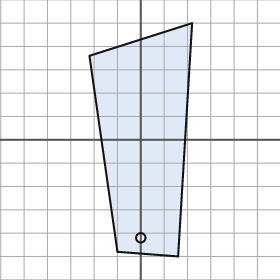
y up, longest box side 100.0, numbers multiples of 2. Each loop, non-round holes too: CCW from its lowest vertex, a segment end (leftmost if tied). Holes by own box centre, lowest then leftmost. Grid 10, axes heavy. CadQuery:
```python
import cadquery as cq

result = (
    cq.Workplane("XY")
    .moveTo(16.0, -50.0)
    .lineTo(22.0, 50.0)
    .lineTo(-22.0, 36.0)
    .lineTo(-10.0, -48.0)
    .close()
    .moveTo(0.0, -42.0)
    .circle(2.0)
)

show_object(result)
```